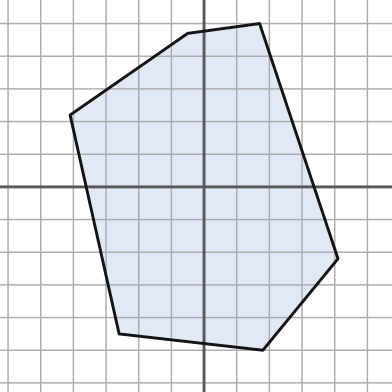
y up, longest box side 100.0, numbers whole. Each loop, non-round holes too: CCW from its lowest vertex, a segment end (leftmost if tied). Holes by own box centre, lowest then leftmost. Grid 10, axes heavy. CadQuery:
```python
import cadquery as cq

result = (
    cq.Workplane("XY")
    .moveTo(18.0, -50.0)
    .lineTo(41.0, -22.0)
    .lineTo(17.0, 50.0)
    .lineTo(-5.0, 47.0)
    .lineTo(-41.0, 22.0)
    .lineTo(-26.0, -45.0)
    .close()
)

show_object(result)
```